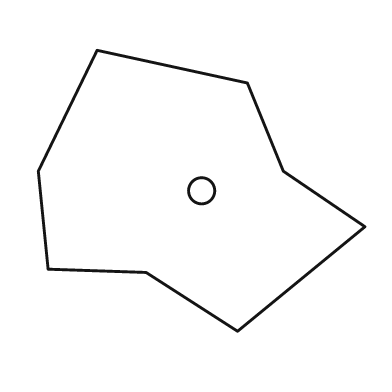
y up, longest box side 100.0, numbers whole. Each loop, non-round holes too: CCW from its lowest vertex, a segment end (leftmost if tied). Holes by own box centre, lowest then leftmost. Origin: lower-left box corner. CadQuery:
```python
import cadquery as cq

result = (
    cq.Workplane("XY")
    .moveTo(61.0, 0.0)
    .lineTo(100.0, 32.0)
    .lineTo(75.0, 49.0)
    .lineTo(64.0, 76.0)
    .lineTo(18.0, 86.0)
    .lineTo(0.0, 49.0)
    .lineTo(3.0, 19.0)
    .lineTo(33.0, 18.0)
    .close()
    .moveTo(50.0, 43.0)
    .circle(4.0)
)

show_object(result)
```